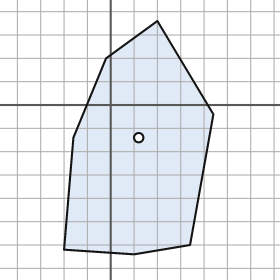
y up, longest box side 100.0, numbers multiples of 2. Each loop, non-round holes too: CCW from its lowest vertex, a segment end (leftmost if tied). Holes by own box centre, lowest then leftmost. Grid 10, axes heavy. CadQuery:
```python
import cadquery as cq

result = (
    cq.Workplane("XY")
    .moveTo(10.0, -64.0)
    .lineTo(34.0, -60.0)
    .lineTo(44.0, -4.0)
    .lineTo(20.0, 36.0)
    .lineTo(-2.0, 20.0)
    .lineTo(-16.0, -14.0)
    .lineTo(-20.0, -62.0)
    .close()
    .moveTo(12.0, -14.0)
    .circle(2.0)
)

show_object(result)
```